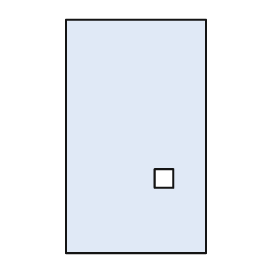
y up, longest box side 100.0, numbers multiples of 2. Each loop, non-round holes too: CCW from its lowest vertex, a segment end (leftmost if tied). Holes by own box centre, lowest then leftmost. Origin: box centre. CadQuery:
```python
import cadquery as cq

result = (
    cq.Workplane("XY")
    .moveTo(-30.0, -50.0)
    .lineTo(30.0, -50.0)
    .lineTo(30.0, 50.0)
    .lineTo(-30.0, 50.0)
    .close()
    .moveTo(8.0, -22.0)
    .lineTo(16.0, -22.0)
    .lineTo(16.0, -14.0)
    .lineTo(8.0, -14.0)
    .close()
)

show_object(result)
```